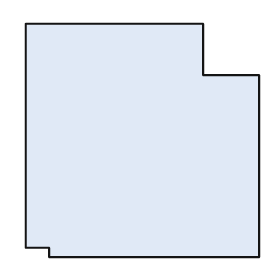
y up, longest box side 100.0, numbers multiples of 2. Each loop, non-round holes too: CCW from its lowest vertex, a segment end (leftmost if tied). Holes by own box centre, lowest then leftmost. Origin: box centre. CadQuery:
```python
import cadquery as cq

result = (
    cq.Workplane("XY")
    .moveTo(-40.0, -50.0)
    .lineTo(50.0, -50.0)
    .lineTo(50.0, 28.0)
    .lineTo(26.0, 28.0)
    .lineTo(26.0, 50.0)
    .lineTo(-50.0, 50.0)
    .lineTo(-50.0, -46.0)
    .lineTo(-40.0, -46.0)
    .close()
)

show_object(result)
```